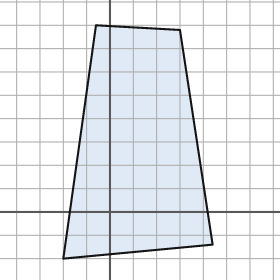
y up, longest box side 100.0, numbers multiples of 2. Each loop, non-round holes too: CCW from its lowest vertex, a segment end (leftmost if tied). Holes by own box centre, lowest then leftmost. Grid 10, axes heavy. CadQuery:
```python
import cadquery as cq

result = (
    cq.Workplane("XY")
    .moveTo(-20.0, -20.0)
    .lineTo(44.0, -14.0)
    .lineTo(30.0, 78.0)
    .lineTo(-6.0, 80.0)
    .close()
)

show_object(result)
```